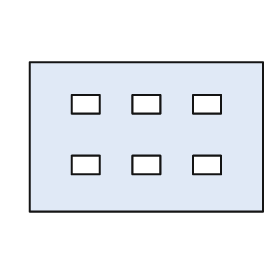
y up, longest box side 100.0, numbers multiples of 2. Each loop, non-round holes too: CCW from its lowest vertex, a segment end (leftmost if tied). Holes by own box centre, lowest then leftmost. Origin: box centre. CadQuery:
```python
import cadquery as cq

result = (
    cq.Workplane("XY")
    .moveTo(-50.0, -32.0)
    .lineTo(50.0, -32.0)
    .lineTo(50.0, 32.0)
    .lineTo(-50.0, 32.0)
    .close()
    .moveTo(-32.0, -16.0)
    .lineTo(-20.0, -16.0)
    .lineTo(-20.0, -8.0)
    .lineTo(-32.0, -8.0)
    .close()
    .moveTo(-6.0, -16.0)
    .lineTo(6.0, -16.0)
    .lineTo(6.0, -8.0)
    .lineTo(-6.0, -8.0)
    .close()
    .moveTo(20.0, -16.0)
    .lineTo(32.0, -16.0)
    .lineTo(32.0, -8.0)
    .lineTo(20.0, -8.0)
    .close()
    .moveTo(-32.0, 10.0)
    .lineTo(-20.0, 10.0)
    .lineTo(-20.0, 18.0)
    .lineTo(-32.0, 18.0)
    .close()
    .moveTo(-6.0, 10.0)
    .lineTo(6.0, 10.0)
    .lineTo(6.0, 18.0)
    .lineTo(-6.0, 18.0)
    .close()
    .moveTo(20.0, 10.0)
    .lineTo(32.0, 10.0)
    .lineTo(32.0, 18.0)
    .lineTo(20.0, 18.0)
    .close()
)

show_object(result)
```